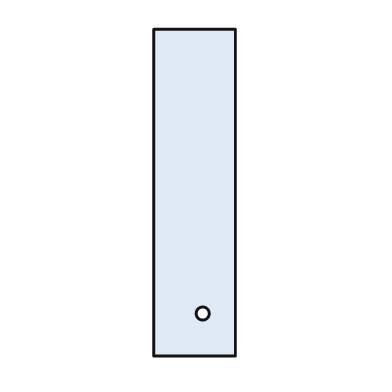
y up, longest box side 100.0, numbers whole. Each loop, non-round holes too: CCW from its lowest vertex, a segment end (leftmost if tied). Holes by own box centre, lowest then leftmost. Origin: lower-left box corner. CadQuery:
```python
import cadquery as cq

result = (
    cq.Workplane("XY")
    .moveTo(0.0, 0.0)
    .lineTo(25.0, 0.0)
    .lineTo(25.0, 100.0)
    .lineTo(0.0, 100.0)
    .close()
    .moveTo(15.0, 13.0)
    .circle(2.0)
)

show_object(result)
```